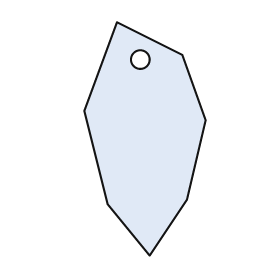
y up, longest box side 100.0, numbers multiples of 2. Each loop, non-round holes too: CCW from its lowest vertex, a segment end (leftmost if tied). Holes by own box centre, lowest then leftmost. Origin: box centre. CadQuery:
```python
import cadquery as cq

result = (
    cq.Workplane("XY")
    .moveTo(2.0, -50.0)
    .lineTo(18.0, -26.0)
    .lineTo(26.0, 8.0)
    .lineTo(16.0, 36.0)
    .lineTo(-12.0, 50.0)
    .lineTo(-26.0, 12.0)
    .lineTo(-16.0, -28.0)
    .close()
    .moveTo(-2.0, 34.0)
    .circle(4.0)
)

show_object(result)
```